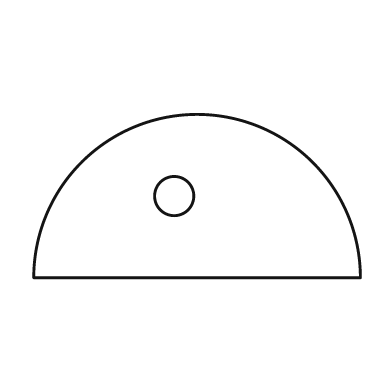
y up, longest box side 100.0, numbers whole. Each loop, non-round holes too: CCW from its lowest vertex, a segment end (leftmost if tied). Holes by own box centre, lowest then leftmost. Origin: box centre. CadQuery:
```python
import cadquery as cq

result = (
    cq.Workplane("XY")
    .moveTo(-50.0, -25.0)
    .lineTo(50.0, -25.0)
    .threePointArc((0.0, 25.0), (-50.0, -25.0))
    .close()
    .moveTo(-7.0, 0.0)
    .circle(6.0)
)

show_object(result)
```